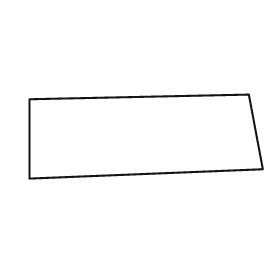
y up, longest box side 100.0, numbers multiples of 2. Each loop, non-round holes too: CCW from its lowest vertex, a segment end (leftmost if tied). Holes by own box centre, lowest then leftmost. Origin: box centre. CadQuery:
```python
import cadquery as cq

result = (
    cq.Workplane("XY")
    .moveTo(-50.0, -18.0)
    .lineTo(50.0, -14.0)
    .lineTo(44.0, 18.0)
    .lineTo(-50.0, 16.0)
    .close()
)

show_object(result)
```